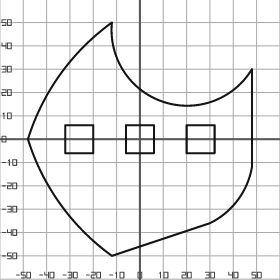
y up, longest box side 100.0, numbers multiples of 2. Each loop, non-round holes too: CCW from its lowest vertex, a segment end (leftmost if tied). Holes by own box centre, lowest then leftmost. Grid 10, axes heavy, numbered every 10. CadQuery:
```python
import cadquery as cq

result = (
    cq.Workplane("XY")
    .moveTo(-12.0, -50.0)
    .lineTo(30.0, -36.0)
    .threePointArc((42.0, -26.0), (48.0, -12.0))
    .lineTo(48.0, 30.0)
    .threePointArc((10.0, 16.0), (-12.0, 50.0))
    .threePointArc((-34.0, 28.0), (-48.0, 0.0))
    .threePointArc((-34.0, -28.0), (-12.0, -50.0))
    .close()
    .moveTo(-32.0, -6.0)
    .lineTo(-20.0, -6.0)
    .lineTo(-20.0, 6.0)
    .lineTo(-32.0, 6.0)
    .close()
    .moveTo(-6.0, -6.0)
    .lineTo(6.0, -6.0)
    .lineTo(6.0, 6.0)
    .lineTo(-6.0, 6.0)
    .close()
    .moveTo(20.0, -6.0)
    .lineTo(32.0, -6.0)
    .lineTo(32.0, 6.0)
    .lineTo(20.0, 6.0)
    .close()
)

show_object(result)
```